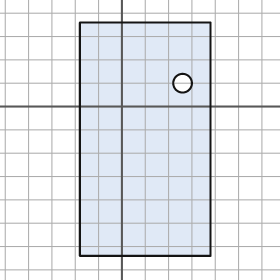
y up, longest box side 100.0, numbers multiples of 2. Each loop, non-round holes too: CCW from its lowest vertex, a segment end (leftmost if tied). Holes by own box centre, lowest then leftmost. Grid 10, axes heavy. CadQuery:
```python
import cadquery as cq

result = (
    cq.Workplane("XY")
    .moveTo(-18.0, -64.0)
    .lineTo(38.0, -64.0)
    .lineTo(38.0, 36.0)
    .lineTo(-18.0, 36.0)
    .close()
    .moveTo(26.0, 10.0)
    .circle(4.0)
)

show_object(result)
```